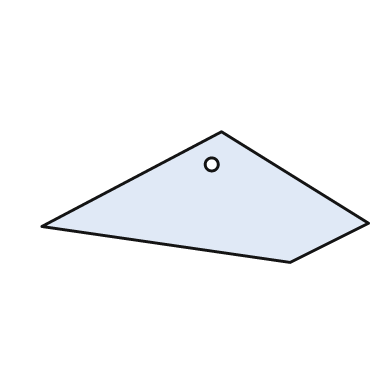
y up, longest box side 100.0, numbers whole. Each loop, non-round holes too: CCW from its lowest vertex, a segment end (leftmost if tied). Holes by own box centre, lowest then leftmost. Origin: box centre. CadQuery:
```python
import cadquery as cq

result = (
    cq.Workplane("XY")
    .moveTo(26.0, -20.0)
    .lineTo(50.0, -8.0)
    .lineTo(5.0, 20.0)
    .lineTo(-50.0, -9.0)
    .close()
    .moveTo(2.0, 10.0)
    .circle(2.0)
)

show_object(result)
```